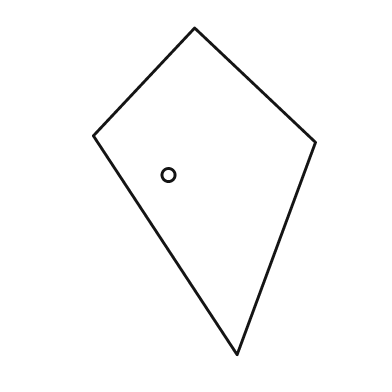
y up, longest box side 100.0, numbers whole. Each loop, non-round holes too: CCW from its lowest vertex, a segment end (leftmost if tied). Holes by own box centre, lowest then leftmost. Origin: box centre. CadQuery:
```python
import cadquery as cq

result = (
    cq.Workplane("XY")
    .moveTo(10.0, -50.0)
    .lineTo(34.0, 15.0)
    .lineTo(-3.0, 50.0)
    .lineTo(-34.0, 17.0)
    .close()
    .moveTo(-11.0, 5.0)
    .circle(2.0)
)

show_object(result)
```